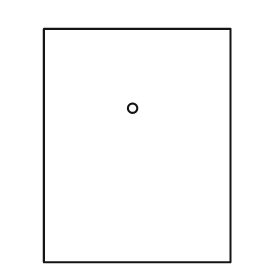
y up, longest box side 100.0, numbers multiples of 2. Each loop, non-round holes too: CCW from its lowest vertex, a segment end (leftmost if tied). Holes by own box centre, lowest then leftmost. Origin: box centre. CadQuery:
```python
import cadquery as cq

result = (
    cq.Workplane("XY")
    .moveTo(-40.0, -50.0)
    .lineTo(40.0, -50.0)
    .lineTo(40.0, 50.0)
    .lineTo(-40.0, 50.0)
    .close()
    .moveTo(-2.0, 16.0)
    .circle(2.0)
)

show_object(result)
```